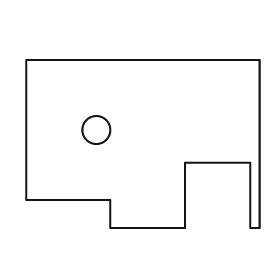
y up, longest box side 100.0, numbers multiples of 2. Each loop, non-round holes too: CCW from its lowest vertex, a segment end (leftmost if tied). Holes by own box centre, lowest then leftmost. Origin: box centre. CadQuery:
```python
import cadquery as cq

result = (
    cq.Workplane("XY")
    .moveTo(-14.0, -36.0)
    .lineTo(18.0, -36.0)
    .lineTo(18.0, -8.0)
    .lineTo(46.0, -8.0)
    .lineTo(46.0, -36.0)
    .lineTo(50.0, -36.0)
    .lineTo(50.0, 36.0)
    .lineTo(-50.0, 36.0)
    .lineTo(-50.0, -24.0)
    .lineTo(-14.0, -24.0)
    .close()
    .moveTo(-20.0, 6.0)
    .circle(6.0)
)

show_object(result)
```